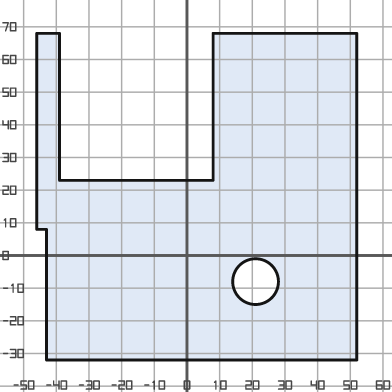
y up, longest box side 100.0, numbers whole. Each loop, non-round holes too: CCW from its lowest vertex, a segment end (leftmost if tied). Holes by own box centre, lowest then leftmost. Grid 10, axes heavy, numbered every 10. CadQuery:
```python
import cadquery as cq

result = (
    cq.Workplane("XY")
    .moveTo(-43.0, -32.0)
    .lineTo(52.0, -32.0)
    .lineTo(52.0, 68.0)
    .lineTo(8.0, 68.0)
    .lineTo(8.0, 23.0)
    .lineTo(-39.0, 23.0)
    .lineTo(-39.0, 68.0)
    .lineTo(-46.0, 68.0)
    .lineTo(-46.0, 8.0)
    .lineTo(-43.0, 8.0)
    .close()
    .moveTo(21.0, -8.0)
    .circle(7.0)
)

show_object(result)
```